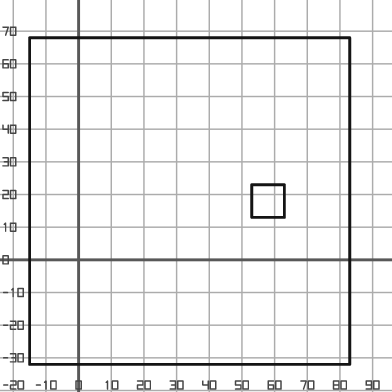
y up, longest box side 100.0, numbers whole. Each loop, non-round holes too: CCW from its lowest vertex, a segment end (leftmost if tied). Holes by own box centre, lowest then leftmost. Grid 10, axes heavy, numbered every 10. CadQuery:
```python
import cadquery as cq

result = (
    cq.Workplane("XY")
    .moveTo(-15.0, -32.0)
    .lineTo(83.0, -32.0)
    .lineTo(83.0, 68.0)
    .lineTo(-15.0, 68.0)
    .close()
    .moveTo(53.0, 13.0)
    .lineTo(63.0, 13.0)
    .lineTo(63.0, 23.0)
    .lineTo(53.0, 23.0)
    .close()
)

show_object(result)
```